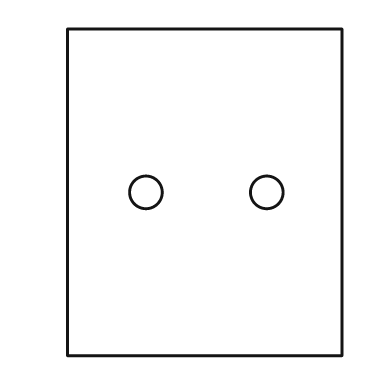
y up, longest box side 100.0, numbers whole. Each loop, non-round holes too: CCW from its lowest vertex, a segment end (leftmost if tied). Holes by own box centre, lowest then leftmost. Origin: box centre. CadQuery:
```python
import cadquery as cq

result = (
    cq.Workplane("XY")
    .moveTo(-42.0, -50.0)
    .lineTo(42.0, -50.0)
    .lineTo(42.0, 50.0)
    .lineTo(-42.0, 50.0)
    .close()
    .moveTo(-18.0, 0.0)
    .circle(5.0)
    .moveTo(19.0, 0.0)
    .circle(5.0)
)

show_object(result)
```